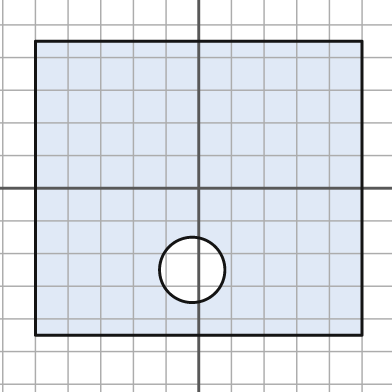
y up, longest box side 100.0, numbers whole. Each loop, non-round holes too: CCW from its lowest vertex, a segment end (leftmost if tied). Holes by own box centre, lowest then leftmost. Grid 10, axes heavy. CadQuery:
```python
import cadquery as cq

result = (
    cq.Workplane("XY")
    .moveTo(-50.0, -45.0)
    .lineTo(50.0, -45.0)
    .lineTo(50.0, 45.0)
    .lineTo(-50.0, 45.0)
    .close()
    .moveTo(-2.0, -25.0)
    .circle(10.0)
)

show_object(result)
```